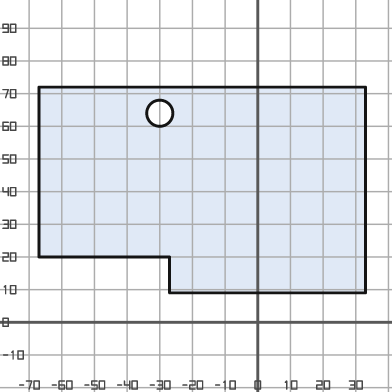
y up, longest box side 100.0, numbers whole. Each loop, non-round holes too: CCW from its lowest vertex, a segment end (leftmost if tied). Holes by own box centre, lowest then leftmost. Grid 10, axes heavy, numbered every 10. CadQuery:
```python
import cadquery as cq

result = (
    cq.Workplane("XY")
    .moveTo(-27.0, 9.0)
    .lineTo(33.0, 9.0)
    .lineTo(33.0, 72.0)
    .lineTo(-67.0, 72.0)
    .lineTo(-67.0, 20.0)
    .lineTo(-27.0, 20.0)
    .close()
    .moveTo(-30.0, 64.0)
    .circle(4.0)
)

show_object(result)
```